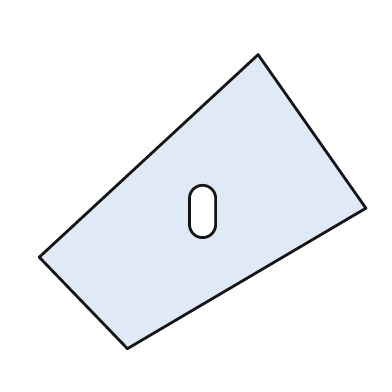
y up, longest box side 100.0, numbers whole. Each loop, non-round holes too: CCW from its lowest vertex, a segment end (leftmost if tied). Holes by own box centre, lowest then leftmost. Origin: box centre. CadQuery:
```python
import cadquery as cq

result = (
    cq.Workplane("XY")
    .moveTo(-23.0, -45.0)
    .lineTo(50.0, -2.0)
    .lineTo(17.0, 45.0)
    .lineTo(-50.0, -17.0)
    .close()
    .moveTo(-4.0, -7.0)
    .threePointArc((0.0, -11.0), (4.0, -7.0))
    .lineTo(4.0, 1.0)
    .threePointArc((0.0, 5.0), (-4.0, 1.0))
    .close()
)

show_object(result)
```